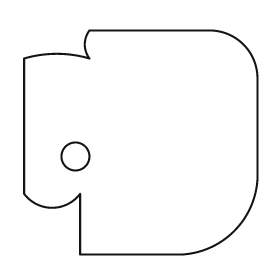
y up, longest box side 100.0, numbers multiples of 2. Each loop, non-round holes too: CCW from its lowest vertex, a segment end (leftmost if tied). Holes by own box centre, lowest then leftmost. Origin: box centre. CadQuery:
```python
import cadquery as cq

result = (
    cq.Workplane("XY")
    .moveTo(-26.0, -48.0)
    .lineTo(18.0, -48.0)
    .threePointArc((40.0, -38.0), (50.0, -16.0))
    .lineTo(50.0, 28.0)
    .threePointArc((44.0, 42.0), (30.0, 48.0))
    .lineTo(-22.0, 48.0)
    .threePointArc((-24.0, 42.0), (-22.0, 36.0))
    .threePointArc((-36.0, 38.0), (-50.0, 36.0))
    .lineTo(-50.0, -22.0)
    .threePointArc((-38.0, -28.0), (-26.0, -22.0))
    .close()
    .moveTo(-28.0, -6.0)
    .circle(6.0)
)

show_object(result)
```